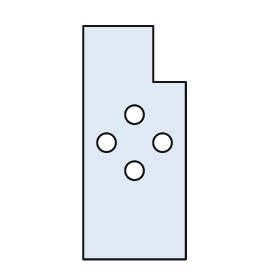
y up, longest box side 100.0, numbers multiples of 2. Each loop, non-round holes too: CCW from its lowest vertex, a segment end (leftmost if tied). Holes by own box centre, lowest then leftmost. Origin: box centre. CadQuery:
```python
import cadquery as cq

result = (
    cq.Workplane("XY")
    .moveTo(-22.0, -50.0)
    .lineTo(22.0, -50.0)
    .lineTo(22.0, 26.0)
    .lineTo(8.0, 26.0)
    .lineTo(8.0, 50.0)
    .lineTo(-22.0, 50.0)
    .close()
    .moveTo(0.0, -12.0)
    .circle(4.0)
    .moveTo(-12.0, 0.0)
    .circle(4.0)
    .moveTo(12.0, 0.0)
    .circle(4.0)
    .moveTo(0.0, 12.0)
    .circle(4.0)
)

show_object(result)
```